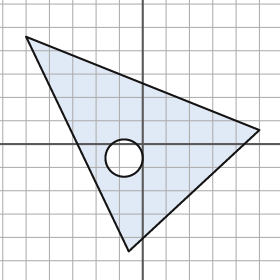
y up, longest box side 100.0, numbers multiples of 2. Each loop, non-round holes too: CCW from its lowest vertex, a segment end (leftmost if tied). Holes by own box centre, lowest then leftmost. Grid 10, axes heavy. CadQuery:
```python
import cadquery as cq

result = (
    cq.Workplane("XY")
    .moveTo(-6.0, -46.0)
    .lineTo(50.0, 6.0)
    .lineTo(-50.0, 46.0)
    .close()
    .moveTo(-8.0, -6.0)
    .circle(8.0)
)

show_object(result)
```